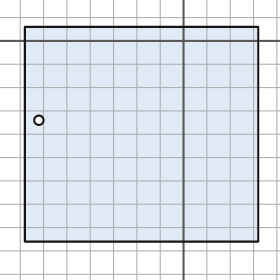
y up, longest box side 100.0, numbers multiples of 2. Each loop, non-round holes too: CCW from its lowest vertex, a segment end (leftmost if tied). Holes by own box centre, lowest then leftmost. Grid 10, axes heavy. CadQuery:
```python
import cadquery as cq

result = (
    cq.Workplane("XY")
    .moveTo(-68.0, -86.0)
    .lineTo(32.0, -86.0)
    .lineTo(32.0, 6.0)
    .lineTo(-68.0, 6.0)
    .close()
    .moveTo(-62.0, -34.0)
    .circle(2.0)
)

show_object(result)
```